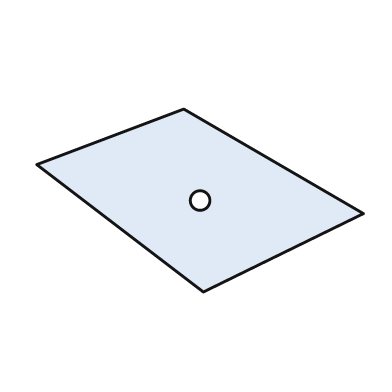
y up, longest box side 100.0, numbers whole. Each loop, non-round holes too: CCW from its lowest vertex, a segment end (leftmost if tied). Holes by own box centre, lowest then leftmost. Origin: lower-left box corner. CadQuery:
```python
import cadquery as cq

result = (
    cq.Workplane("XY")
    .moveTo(51.0, 0.0)
    .lineTo(100.0, 24.0)
    .lineTo(45.0, 56.0)
    .lineTo(0.0, 39.0)
    .close()
    .moveTo(50.0, 28.0)
    .circle(3.0)
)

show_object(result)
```